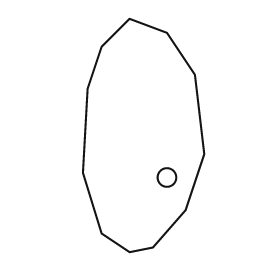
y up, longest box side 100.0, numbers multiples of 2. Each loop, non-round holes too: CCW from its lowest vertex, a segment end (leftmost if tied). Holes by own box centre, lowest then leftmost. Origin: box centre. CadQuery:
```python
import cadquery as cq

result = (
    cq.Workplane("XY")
    .moveTo(-6.0, -50.0)
    .lineTo(4.0, -48.0)
    .lineTo(18.0, -32.0)
    .lineTo(26.0, -8.0)
    .lineTo(22.0, 26.0)
    .lineTo(10.0, 44.0)
    .lineTo(-6.0, 50.0)
    .lineTo(-18.0, 38.0)
    .lineTo(-24.0, 20.0)
    .lineTo(-26.0, -16.0)
    .lineTo(-18.0, -42.0)
    .close()
    .moveTo(10.0, -18.0)
    .circle(4.0)
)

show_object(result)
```